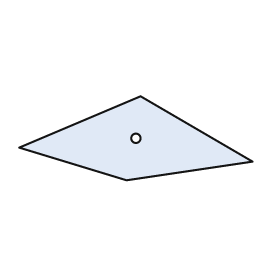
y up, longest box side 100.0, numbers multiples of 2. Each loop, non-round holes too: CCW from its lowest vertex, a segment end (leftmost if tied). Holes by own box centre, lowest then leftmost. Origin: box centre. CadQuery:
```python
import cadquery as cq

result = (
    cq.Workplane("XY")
    .moveTo(-4.0, -18.0)
    .lineTo(50.0, -10.0)
    .lineTo(2.0, 18.0)
    .lineTo(-50.0, -4.0)
    .close()
    .moveTo(0.0, 0.0)
    .circle(2.0)
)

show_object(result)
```